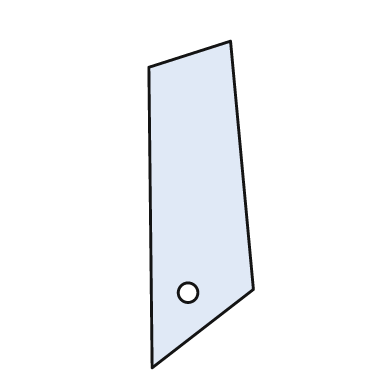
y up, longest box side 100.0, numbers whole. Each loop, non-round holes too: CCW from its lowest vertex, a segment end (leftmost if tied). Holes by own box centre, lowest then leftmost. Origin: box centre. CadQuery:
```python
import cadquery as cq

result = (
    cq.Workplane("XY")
    .moveTo(-15.0, -50.0)
    .lineTo(16.0, -26.0)
    .lineTo(9.0, 50.0)
    .lineTo(-16.0, 42.0)
    .close()
    .moveTo(-4.0, -27.0)
    .circle(3.0)
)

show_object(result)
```